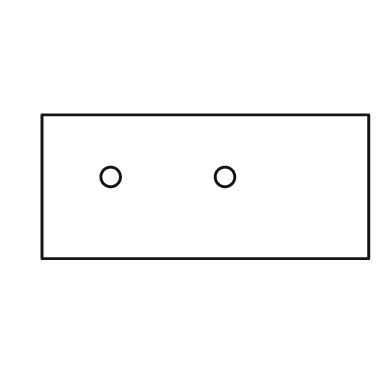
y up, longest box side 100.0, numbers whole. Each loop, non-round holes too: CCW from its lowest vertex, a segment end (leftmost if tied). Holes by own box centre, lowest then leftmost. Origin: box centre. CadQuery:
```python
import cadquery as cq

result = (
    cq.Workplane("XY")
    .moveTo(-50.0, -22.0)
    .lineTo(50.0, -22.0)
    .lineTo(50.0, 22.0)
    .lineTo(-50.0, 22.0)
    .close()
    .moveTo(-29.0, 3.0)
    .circle(3.0)
    .moveTo(6.0, 3.0)
    .circle(3.0)
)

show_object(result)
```